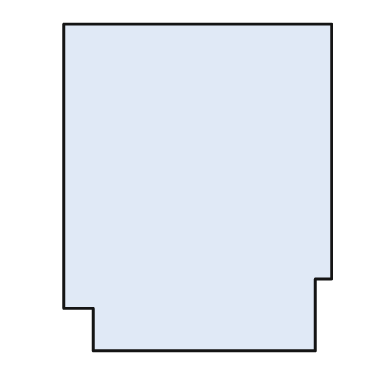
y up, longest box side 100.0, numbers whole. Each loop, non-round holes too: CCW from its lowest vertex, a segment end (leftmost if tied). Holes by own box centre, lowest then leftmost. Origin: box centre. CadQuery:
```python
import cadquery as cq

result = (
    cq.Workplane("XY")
    .moveTo(-32.0, -50.0)
    .lineTo(36.0, -50.0)
    .lineTo(36.0, -28.0)
    .lineTo(41.0, -28.0)
    .lineTo(41.0, 50.0)
    .lineTo(-41.0, 50.0)
    .lineTo(-41.0, -37.0)
    .lineTo(-32.0, -37.0)
    .close()
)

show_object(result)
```